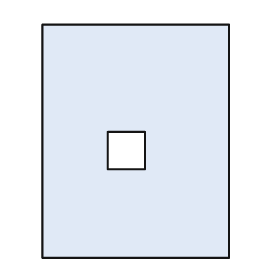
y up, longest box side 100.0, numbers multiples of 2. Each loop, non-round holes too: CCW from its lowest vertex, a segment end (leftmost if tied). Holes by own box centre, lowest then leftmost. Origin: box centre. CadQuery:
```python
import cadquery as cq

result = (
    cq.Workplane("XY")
    .moveTo(-40.0, -50.0)
    .lineTo(40.0, -50.0)
    .lineTo(40.0, 50.0)
    .lineTo(-40.0, 50.0)
    .close()
    .moveTo(-12.0, -12.0)
    .lineTo(4.0, -12.0)
    .lineTo(4.0, 4.0)
    .lineTo(-12.0, 4.0)
    .close()
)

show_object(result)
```